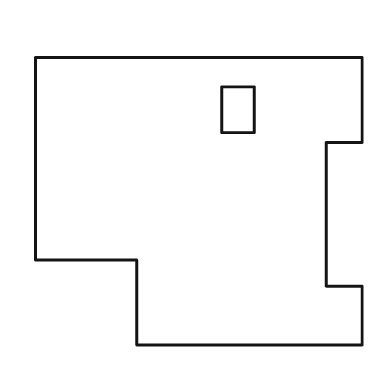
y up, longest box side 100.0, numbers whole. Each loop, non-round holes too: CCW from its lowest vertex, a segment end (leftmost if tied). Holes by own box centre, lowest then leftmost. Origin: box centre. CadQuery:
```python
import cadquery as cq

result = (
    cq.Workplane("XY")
    .moveTo(-19.0, -44.0)
    .lineTo(50.0, -44.0)
    .lineTo(50.0, -26.0)
    .lineTo(39.0, -26.0)
    .lineTo(39.0, 18.0)
    .lineTo(50.0, 18.0)
    .lineTo(50.0, 44.0)
    .lineTo(-50.0, 44.0)
    .lineTo(-50.0, -18.0)
    .lineTo(-19.0, -18.0)
    .close()
    .moveTo(7.0, 21.0)
    .lineTo(17.0, 21.0)
    .lineTo(17.0, 35.0)
    .lineTo(7.0, 35.0)
    .close()
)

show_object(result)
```